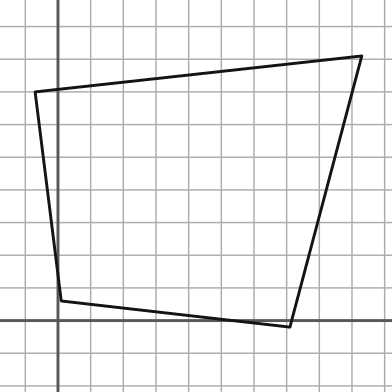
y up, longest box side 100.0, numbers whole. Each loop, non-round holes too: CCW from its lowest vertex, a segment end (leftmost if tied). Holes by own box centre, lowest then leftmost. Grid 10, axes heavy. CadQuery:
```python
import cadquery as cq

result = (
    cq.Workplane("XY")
    .moveTo(71.0, -2.0)
    .lineTo(93.0, 81.0)
    .lineTo(-7.0, 70.0)
    .lineTo(1.0, 6.0)
    .close()
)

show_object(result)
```